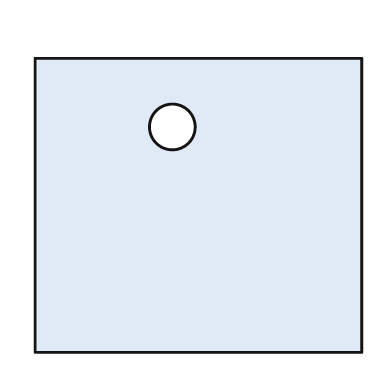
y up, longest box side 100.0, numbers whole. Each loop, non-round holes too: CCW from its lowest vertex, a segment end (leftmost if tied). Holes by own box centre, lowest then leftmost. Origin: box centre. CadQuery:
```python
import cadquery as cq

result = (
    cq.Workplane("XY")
    .moveTo(-50.0, -45.0)
    .lineTo(50.0, -45.0)
    .lineTo(50.0, 45.0)
    .lineTo(-50.0, 45.0)
    .close()
    .moveTo(-8.0, 24.0)
    .circle(7.0)
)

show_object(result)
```